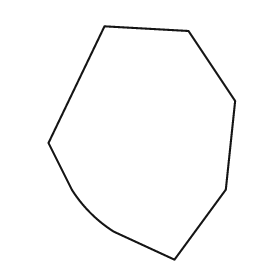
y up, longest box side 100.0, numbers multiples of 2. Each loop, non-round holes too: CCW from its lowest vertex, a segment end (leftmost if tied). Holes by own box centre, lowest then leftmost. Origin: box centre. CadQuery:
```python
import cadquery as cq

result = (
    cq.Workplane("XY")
    .moveTo(14.0, -50.0)
    .lineTo(36.0, -20.0)
    .lineTo(40.0, 18.0)
    .lineTo(20.0, 48.0)
    .lineTo(-16.0, 50.0)
    .lineTo(-40.0, 0.0)
    .lineTo(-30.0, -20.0)
    .threePointArc((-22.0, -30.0), (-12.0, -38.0))
    .close()
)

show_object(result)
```